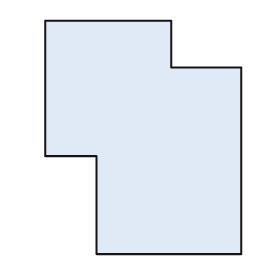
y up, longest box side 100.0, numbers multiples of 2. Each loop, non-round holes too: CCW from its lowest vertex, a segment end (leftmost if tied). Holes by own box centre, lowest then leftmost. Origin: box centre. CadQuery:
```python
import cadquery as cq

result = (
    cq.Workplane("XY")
    .moveTo(-20.0, -50.0)
    .lineTo(42.0, -50.0)
    .lineTo(42.0, 30.0)
    .lineTo(12.0, 30.0)
    .lineTo(12.0, 50.0)
    .lineTo(-42.0, 50.0)
    .lineTo(-42.0, -8.0)
    .lineTo(-20.0, -8.0)
    .close()
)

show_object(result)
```